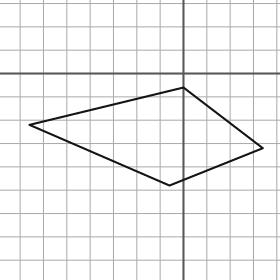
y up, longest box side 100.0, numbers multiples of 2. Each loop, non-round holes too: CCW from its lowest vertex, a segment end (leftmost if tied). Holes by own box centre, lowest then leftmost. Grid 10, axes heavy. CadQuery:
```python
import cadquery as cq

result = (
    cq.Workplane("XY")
    .moveTo(-6.0, -48.0)
    .lineTo(34.0, -32.0)
    .lineTo(0.0, -6.0)
    .lineTo(-66.0, -22.0)
    .close()
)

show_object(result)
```